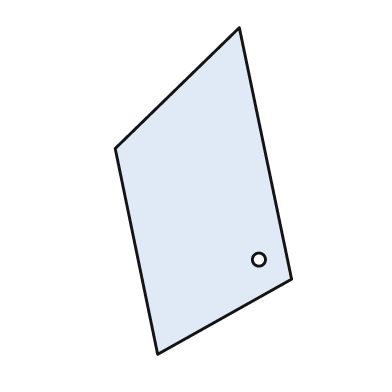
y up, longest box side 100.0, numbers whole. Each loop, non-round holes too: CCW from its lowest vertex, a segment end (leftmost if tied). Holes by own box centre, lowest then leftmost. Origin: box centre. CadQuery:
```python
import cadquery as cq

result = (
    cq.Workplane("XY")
    .moveTo(-14.0, -50.0)
    .lineTo(27.0, -27.0)
    .lineTo(11.0, 50.0)
    .lineTo(-27.0, 13.0)
    .close()
    .moveTo(17.0, -21.0)
    .circle(2.0)
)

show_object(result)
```